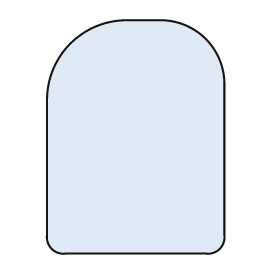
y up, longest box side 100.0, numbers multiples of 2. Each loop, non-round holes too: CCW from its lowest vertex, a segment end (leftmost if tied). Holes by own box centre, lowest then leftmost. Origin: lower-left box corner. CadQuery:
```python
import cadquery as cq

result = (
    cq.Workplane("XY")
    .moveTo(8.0, 0.0)
    .lineTo(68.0, 0.0)
    .threePointArc((74.0, 2.0), (76.0, 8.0))
    .lineTo(76.0, 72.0)
    .threePointArc((68.0, 92.0), (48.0, 100.0))
    .lineTo(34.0, 100.0)
    .threePointArc((10.0, 90.0), (0.0, 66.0))
    .lineTo(0.0, 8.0)
    .threePointArc((2.0, 2.0), (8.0, 0.0))
    .close()
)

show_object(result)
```